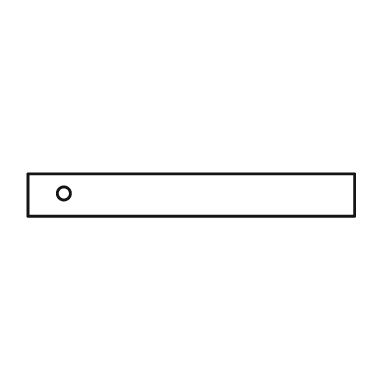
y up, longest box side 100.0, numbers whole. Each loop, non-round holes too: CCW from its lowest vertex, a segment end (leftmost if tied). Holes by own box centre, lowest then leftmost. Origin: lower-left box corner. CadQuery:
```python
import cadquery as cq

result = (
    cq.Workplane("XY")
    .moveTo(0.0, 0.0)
    .lineTo(100.0, 0.0)
    .lineTo(100.0, 13.0)
    .lineTo(0.0, 13.0)
    .close()
    .moveTo(11.0, 7.0)
    .circle(2.0)
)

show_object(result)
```